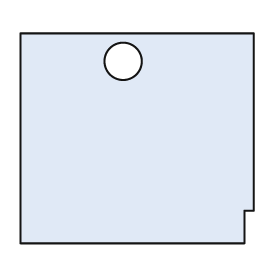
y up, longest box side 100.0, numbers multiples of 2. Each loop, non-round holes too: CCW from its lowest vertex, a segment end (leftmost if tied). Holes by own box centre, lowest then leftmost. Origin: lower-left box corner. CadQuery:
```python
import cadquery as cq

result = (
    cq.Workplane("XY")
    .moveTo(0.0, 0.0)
    .lineTo(96.0, 0.0)
    .lineTo(96.0, 14.0)
    .lineTo(100.0, 14.0)
    .lineTo(100.0, 90.0)
    .lineTo(0.0, 90.0)
    .close()
    .moveTo(44.0, 78.0)
    .circle(8.0)
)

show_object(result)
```